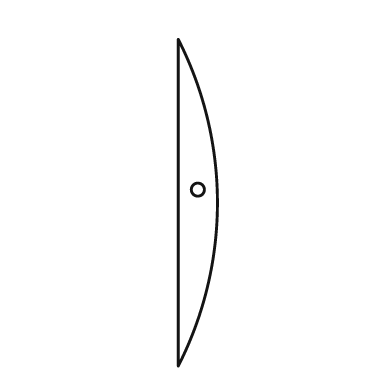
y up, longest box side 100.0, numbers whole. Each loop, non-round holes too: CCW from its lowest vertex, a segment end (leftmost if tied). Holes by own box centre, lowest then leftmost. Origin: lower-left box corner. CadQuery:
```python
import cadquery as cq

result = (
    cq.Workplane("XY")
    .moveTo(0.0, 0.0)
    .threePointArc((12.0, 50.0), (0.0, 100.0))
    .close()
    .moveTo(6.0, 54.0)
    .circle(2.0)
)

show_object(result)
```